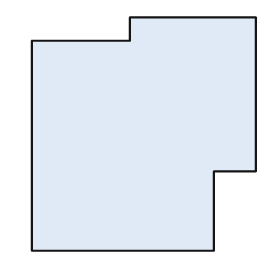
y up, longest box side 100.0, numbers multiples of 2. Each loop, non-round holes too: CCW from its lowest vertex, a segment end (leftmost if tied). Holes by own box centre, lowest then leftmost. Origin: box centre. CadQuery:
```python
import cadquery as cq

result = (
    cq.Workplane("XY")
    .moveTo(-48.0, -50.0)
    .lineTo(30.0, -50.0)
    .lineTo(30.0, -16.0)
    .lineTo(48.0, -16.0)
    .lineTo(48.0, 50.0)
    .lineTo(-6.0, 50.0)
    .lineTo(-6.0, 40.0)
    .lineTo(-48.0, 40.0)
    .close()
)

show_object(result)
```